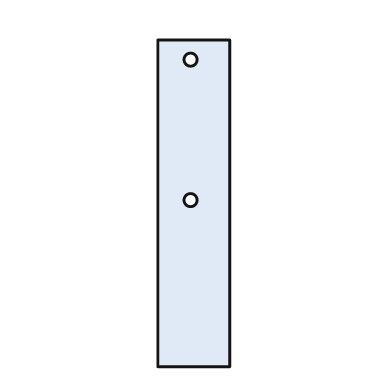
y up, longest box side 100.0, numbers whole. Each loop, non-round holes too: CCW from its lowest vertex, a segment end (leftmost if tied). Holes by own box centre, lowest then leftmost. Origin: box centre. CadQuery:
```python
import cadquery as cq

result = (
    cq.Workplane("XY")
    .moveTo(-11.0, -50.0)
    .lineTo(11.0, -50.0)
    .lineTo(11.0, 50.0)
    .lineTo(-11.0, 50.0)
    .close()
    .moveTo(-1.0, 1.0)
    .circle(2.0)
    .moveTo(-1.0, 44.0)
    .circle(2.0)
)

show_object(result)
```